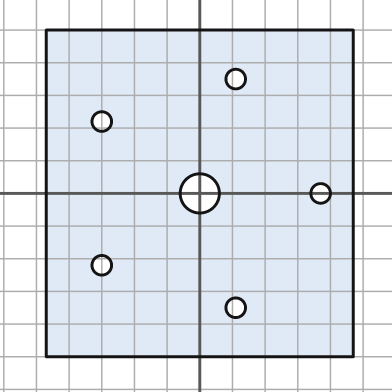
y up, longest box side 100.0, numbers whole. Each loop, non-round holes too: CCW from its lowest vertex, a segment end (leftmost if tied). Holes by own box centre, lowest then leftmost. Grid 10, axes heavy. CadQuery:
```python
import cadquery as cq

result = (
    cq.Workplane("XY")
    .moveTo(-47.0, -50.0)
    .lineTo(47.0, -50.0)
    .lineTo(47.0, 50.0)
    .lineTo(-47.0, 50.0)
    .close()
    .moveTo(11.0, -35.0)
    .circle(3.0)
    .moveTo(-30.0, -22.0)
    .circle(3.0)
    .moveTo(0.0, 0.0)
    .circle(6.0)
    .moveTo(37.0, 0.0)
    .circle(3.0)
    .moveTo(-30.0, 22.0)
    .circle(3.0)
    .moveTo(11.0, 35.0)
    .circle(3.0)
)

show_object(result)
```